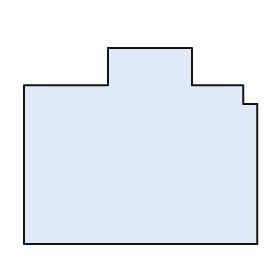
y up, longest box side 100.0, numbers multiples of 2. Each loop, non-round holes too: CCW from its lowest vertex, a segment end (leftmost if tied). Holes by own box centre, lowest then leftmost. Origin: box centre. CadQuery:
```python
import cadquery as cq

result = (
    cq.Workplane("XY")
    .moveTo(-50.0, -42.0)
    .lineTo(50.0, -42.0)
    .lineTo(50.0, 18.0)
    .lineTo(44.0, 18.0)
    .lineTo(44.0, 26.0)
    .lineTo(22.0, 26.0)
    .lineTo(22.0, 42.0)
    .lineTo(-14.0, 42.0)
    .lineTo(-14.0, 26.0)
    .lineTo(-50.0, 26.0)
    .close()
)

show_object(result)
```